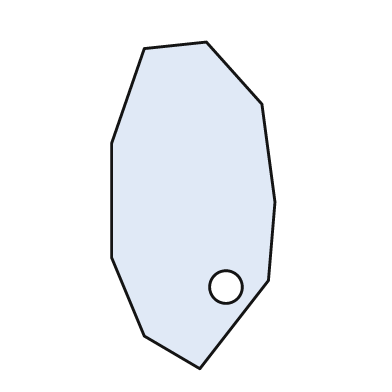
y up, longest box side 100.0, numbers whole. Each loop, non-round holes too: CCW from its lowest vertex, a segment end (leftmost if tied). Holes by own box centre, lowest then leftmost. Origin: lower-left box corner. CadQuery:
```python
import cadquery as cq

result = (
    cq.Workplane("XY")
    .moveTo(27.0, 0.0)
    .lineTo(48.0, 27.0)
    .lineTo(50.0, 51.0)
    .lineTo(46.0, 81.0)
    .lineTo(29.0, 100.0)
    .lineTo(10.0, 98.0)
    .lineTo(0.0, 69.0)
    .lineTo(0.0, 34.0)
    .lineTo(10.0, 10.0)
    .close()
    .moveTo(35.0, 25.0)
    .circle(5.0)
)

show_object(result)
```